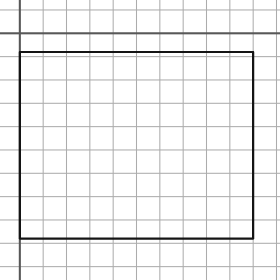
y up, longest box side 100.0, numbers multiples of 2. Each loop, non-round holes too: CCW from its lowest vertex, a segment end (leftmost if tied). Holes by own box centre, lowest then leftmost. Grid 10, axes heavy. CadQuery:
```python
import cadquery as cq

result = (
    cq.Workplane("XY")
    .moveTo(0.0, -88.0)
    .lineTo(100.0, -88.0)
    .lineTo(100.0, -8.0)
    .lineTo(0.0, -8.0)
    .close()
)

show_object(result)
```